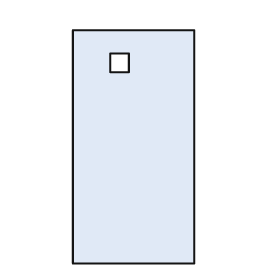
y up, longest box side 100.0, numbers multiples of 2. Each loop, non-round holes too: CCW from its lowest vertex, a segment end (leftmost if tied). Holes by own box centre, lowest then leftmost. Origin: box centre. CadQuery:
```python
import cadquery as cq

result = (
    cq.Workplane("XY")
    .moveTo(-26.0, -50.0)
    .lineTo(26.0, -50.0)
    .lineTo(26.0, 50.0)
    .lineTo(-26.0, 50.0)
    .close()
    .moveTo(-10.0, 32.0)
    .lineTo(-2.0, 32.0)
    .lineTo(-2.0, 40.0)
    .lineTo(-10.0, 40.0)
    .close()
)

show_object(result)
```